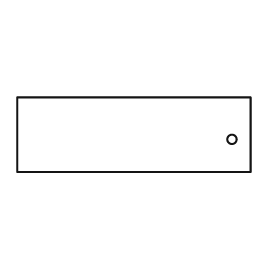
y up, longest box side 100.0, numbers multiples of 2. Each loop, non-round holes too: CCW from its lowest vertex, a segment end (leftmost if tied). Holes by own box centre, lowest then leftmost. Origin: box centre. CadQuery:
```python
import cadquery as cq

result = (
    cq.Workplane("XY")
    .moveTo(-50.0, -16.0)
    .lineTo(50.0, -16.0)
    .lineTo(50.0, 16.0)
    .lineTo(-50.0, 16.0)
    .close()
    .moveTo(42.0, -2.0)
    .circle(2.0)
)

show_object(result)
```